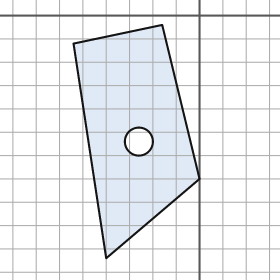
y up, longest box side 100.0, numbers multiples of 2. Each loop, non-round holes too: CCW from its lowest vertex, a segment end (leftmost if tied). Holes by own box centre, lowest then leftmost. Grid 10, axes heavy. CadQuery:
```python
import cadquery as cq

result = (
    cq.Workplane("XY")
    .moveTo(-40.0, -104.0)
    .lineTo(0.0, -70.0)
    .lineTo(-16.0, -4.0)
    .lineTo(-54.0, -12.0)
    .close()
    .moveTo(-26.0, -54.0)
    .circle(6.0)
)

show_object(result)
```